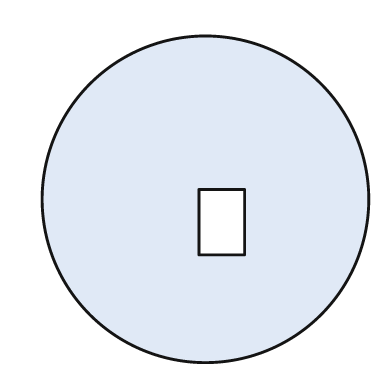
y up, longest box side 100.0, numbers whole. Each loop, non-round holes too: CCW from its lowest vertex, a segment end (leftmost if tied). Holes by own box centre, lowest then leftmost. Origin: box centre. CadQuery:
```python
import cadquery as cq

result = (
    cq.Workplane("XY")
    .moveTo(0.0, 0.0)
    .circle(50.0)
    .moveTo(-2.0, -17.0)
    .lineTo(12.0, -17.0)
    .lineTo(12.0, 3.0)
    .lineTo(-2.0, 3.0)
    .close()
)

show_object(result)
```